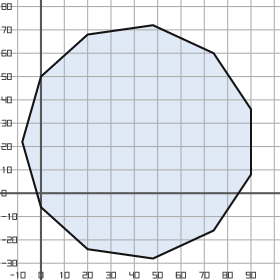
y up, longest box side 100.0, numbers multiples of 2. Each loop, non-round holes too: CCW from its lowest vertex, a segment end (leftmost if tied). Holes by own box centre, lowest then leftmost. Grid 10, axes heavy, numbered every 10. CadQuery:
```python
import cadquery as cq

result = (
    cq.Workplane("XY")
    .moveTo(48.0, -28.0)
    .lineTo(74.0, -16.0)
    .lineTo(90.0, 8.0)
    .lineTo(90.0, 36.0)
    .lineTo(74.0, 60.0)
    .lineTo(48.0, 72.0)
    .lineTo(20.0, 68.0)
    .lineTo(0.0, 50.0)
    .lineTo(-8.0, 22.0)
    .lineTo(0.0, -6.0)
    .lineTo(20.0, -24.0)
    .close()
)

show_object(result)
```